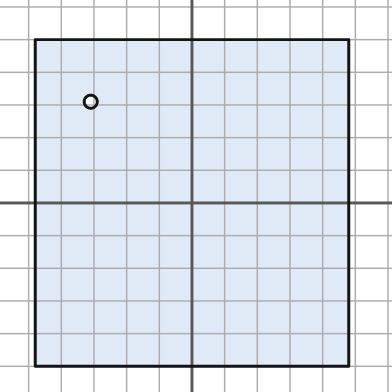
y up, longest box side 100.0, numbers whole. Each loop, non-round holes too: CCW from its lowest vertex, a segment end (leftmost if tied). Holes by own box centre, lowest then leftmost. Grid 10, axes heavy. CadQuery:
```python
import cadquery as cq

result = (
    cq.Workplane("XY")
    .moveTo(-48.0, -50.0)
    .lineTo(48.0, -50.0)
    .lineTo(48.0, 50.0)
    .lineTo(-48.0, 50.0)
    .close()
    .moveTo(-31.0, 31.0)
    .circle(2.0)
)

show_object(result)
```